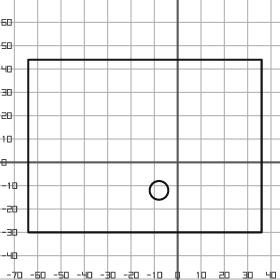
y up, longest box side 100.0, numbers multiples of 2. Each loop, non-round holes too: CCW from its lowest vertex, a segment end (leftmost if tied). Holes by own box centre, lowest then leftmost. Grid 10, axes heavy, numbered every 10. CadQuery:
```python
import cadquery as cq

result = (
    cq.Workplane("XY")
    .moveTo(-64.0, -30.0)
    .lineTo(36.0, -30.0)
    .lineTo(36.0, 44.0)
    .lineTo(-64.0, 44.0)
    .close()
    .moveTo(-8.0, -12.0)
    .circle(4.0)
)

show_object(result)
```